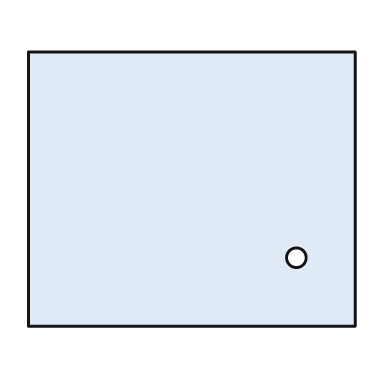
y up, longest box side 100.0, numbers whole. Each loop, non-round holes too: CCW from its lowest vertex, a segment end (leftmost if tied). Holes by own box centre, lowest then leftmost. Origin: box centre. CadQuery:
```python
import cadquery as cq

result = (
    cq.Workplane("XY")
    .moveTo(-50.0, -42.0)
    .lineTo(50.0, -42.0)
    .lineTo(50.0, 42.0)
    .lineTo(-50.0, 42.0)
    .close()
    .moveTo(32.0, -21.0)
    .circle(3.0)
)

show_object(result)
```